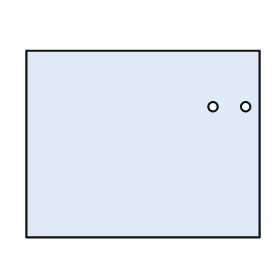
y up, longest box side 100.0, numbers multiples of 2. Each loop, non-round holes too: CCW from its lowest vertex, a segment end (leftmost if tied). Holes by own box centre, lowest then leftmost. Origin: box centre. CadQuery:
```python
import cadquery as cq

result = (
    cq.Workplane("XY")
    .moveTo(-50.0, -40.0)
    .lineTo(50.0, -40.0)
    .lineTo(50.0, 40.0)
    .lineTo(-50.0, 40.0)
    .close()
    .moveTo(30.0, 16.0)
    .circle(2.0)
    .moveTo(44.0, 16.0)
    .circle(2.0)
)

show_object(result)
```